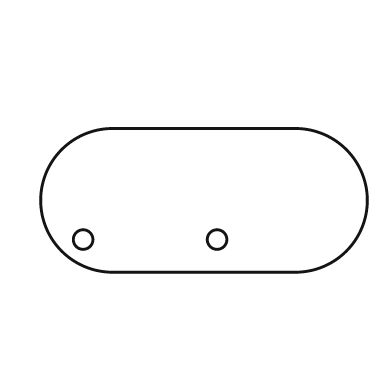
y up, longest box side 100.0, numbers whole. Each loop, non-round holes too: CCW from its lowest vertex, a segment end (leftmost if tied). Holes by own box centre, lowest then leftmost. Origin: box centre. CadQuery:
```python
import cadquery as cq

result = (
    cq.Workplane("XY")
    .moveTo(-28.0, -22.0)
    .lineTo(28.0, -22.0)
    .threePointArc((50.0, 0.0), (28.0, 22.0))
    .lineTo(-28.0, 22.0)
    .threePointArc((-50.0, 0.0), (-28.0, -22.0))
    .close()
    .moveTo(-37.0, -12.0)
    .circle(3.0)
    .moveTo(4.0, -12.0)
    .circle(3.0)
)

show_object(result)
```